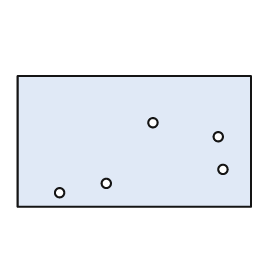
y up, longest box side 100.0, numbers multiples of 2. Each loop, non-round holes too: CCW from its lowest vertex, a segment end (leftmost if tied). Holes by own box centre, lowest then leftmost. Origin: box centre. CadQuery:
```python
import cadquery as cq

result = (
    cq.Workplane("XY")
    .moveTo(-50.0, -28.0)
    .lineTo(50.0, -28.0)
    .lineTo(50.0, 28.0)
    .lineTo(-50.0, 28.0)
    .close()
    .moveTo(-32.0, -22.0)
    .circle(2.0)
    .moveTo(-12.0, -18.0)
    .circle(2.0)
    .moveTo(38.0, -12.0)
    .circle(2.0)
    .moveTo(36.0, 2.0)
    .circle(2.0)
    .moveTo(8.0, 8.0)
    .circle(2.0)
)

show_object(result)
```